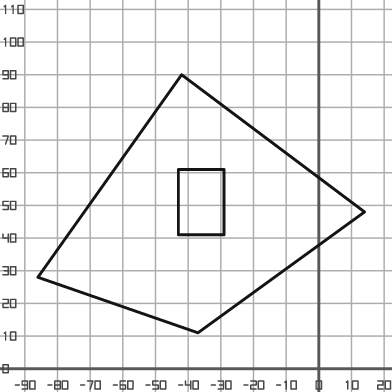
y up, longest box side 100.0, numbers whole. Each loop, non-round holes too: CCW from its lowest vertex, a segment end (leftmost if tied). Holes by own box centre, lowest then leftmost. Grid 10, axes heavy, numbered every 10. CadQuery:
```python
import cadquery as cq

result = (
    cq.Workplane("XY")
    .moveTo(-37.0, 11.0)
    .lineTo(14.0, 48.0)
    .lineTo(-42.0, 90.0)
    .lineTo(-86.0, 28.0)
    .close()
    .moveTo(-43.0, 41.0)
    .lineTo(-29.0, 41.0)
    .lineTo(-29.0, 61.0)
    .lineTo(-43.0, 61.0)
    .close()
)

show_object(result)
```